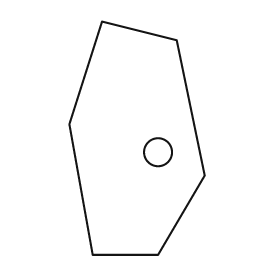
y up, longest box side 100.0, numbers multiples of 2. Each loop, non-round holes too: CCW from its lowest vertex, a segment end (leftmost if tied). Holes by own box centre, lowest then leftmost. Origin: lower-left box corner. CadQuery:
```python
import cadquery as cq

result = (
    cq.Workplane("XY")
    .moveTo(10.0, 0.0)
    .lineTo(38.0, 0.0)
    .lineTo(58.0, 34.0)
    .lineTo(46.0, 92.0)
    .lineTo(14.0, 100.0)
    .lineTo(0.0, 56.0)
    .close()
    .moveTo(38.0, 44.0)
    .circle(6.0)
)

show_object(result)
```